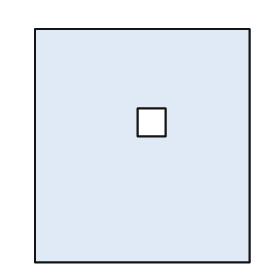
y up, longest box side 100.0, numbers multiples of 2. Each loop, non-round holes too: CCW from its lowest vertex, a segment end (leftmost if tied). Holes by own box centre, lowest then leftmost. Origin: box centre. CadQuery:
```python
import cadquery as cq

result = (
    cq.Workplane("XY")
    .moveTo(-46.0, -50.0)
    .lineTo(46.0, -50.0)
    .lineTo(46.0, 50.0)
    .lineTo(-46.0, 50.0)
    .close()
    .moveTo(-2.0, 4.0)
    .lineTo(10.0, 4.0)
    .lineTo(10.0, 16.0)
    .lineTo(-2.0, 16.0)
    .close()
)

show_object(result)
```